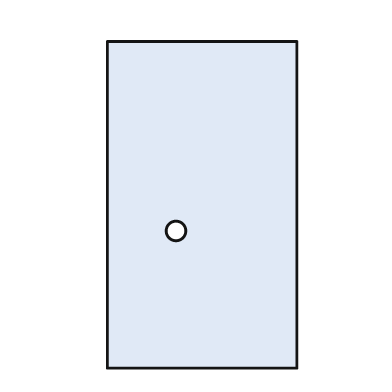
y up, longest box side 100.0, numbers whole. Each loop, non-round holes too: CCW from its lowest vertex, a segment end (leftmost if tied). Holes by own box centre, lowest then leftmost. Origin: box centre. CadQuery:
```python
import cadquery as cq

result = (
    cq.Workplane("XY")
    .moveTo(-29.0, -50.0)
    .lineTo(29.0, -50.0)
    .lineTo(29.0, 50.0)
    .lineTo(-29.0, 50.0)
    .close()
    .moveTo(-8.0, -8.0)
    .circle(3.0)
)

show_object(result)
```